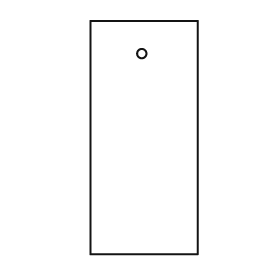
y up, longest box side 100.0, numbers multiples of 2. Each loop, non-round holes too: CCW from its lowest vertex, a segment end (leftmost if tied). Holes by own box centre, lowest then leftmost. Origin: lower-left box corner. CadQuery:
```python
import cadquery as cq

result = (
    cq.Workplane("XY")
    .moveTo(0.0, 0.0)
    .lineTo(46.0, 0.0)
    .lineTo(46.0, 100.0)
    .lineTo(0.0, 100.0)
    .close()
    .moveTo(22.0, 86.0)
    .circle(2.0)
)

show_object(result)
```